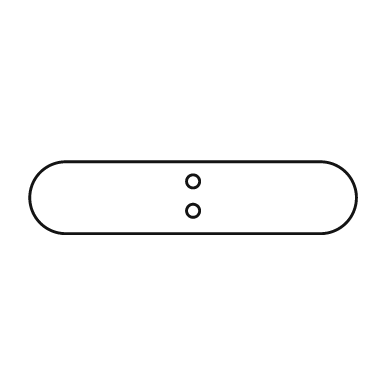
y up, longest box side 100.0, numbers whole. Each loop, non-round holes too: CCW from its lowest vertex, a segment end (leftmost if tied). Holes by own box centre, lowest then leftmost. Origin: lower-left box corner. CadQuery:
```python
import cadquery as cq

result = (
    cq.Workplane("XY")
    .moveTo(11.0, 0.0)
    .lineTo(89.0, 0.0)
    .threePointArc((100.0, 11.0), (89.0, 22.0))
    .lineTo(11.0, 22.0)
    .threePointArc((0.0, 11.0), (11.0, 0.0))
    .close()
    .moveTo(50.0, 7.0)
    .circle(2.0)
    .moveTo(50.0, 16.0)
    .circle(2.0)
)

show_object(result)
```